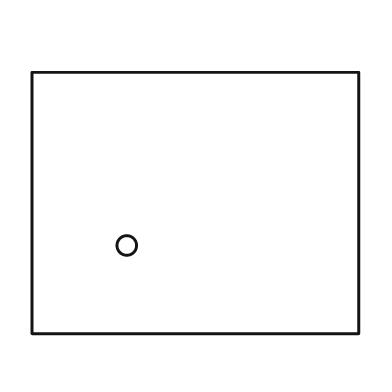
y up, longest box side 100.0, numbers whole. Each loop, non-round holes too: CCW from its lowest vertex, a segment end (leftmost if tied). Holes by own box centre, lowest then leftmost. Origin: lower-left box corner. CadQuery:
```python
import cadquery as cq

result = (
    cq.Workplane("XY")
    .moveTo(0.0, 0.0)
    .lineTo(100.0, 0.0)
    .lineTo(100.0, 80.0)
    .lineTo(0.0, 80.0)
    .close()
    .moveTo(29.0, 27.0)
    .circle(3.0)
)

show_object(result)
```